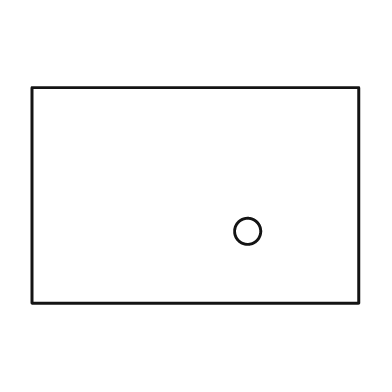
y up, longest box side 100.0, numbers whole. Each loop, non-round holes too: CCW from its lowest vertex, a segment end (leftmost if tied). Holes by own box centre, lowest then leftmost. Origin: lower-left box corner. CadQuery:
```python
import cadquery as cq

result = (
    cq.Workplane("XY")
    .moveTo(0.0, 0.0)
    .lineTo(100.0, 0.0)
    .lineTo(100.0, 66.0)
    .lineTo(0.0, 66.0)
    .close()
    .moveTo(66.0, 22.0)
    .circle(4.0)
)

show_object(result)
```